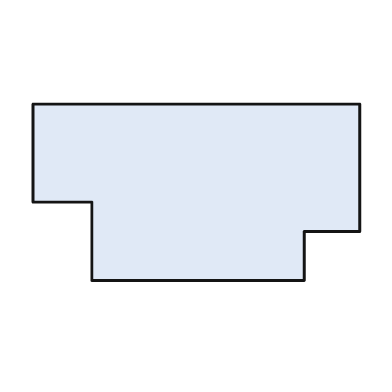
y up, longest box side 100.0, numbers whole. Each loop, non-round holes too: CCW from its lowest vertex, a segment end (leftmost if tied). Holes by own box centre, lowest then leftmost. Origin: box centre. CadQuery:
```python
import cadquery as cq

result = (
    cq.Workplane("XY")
    .moveTo(-32.0, -27.0)
    .lineTo(33.0, -27.0)
    .lineTo(33.0, -12.0)
    .lineTo(50.0, -12.0)
    .lineTo(50.0, 27.0)
    .lineTo(-50.0, 27.0)
    .lineTo(-50.0, -3.0)
    .lineTo(-32.0, -3.0)
    .close()
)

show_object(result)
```